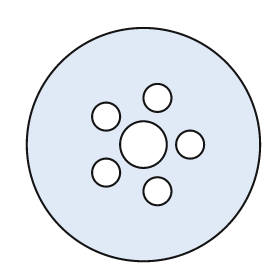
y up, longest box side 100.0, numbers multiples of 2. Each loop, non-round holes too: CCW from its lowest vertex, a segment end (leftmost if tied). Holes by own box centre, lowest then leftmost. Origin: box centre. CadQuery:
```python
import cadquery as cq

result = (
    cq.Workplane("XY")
    .moveTo(0.0, 0.0)
    .circle(50.0)
    .moveTo(6.0, -20.0)
    .circle(6.0)
    .moveTo(-16.0, -12.0)
    .circle(6.0)
    .moveTo(0.0, 0.0)
    .circle(10.0)
    .moveTo(20.0, 0.0)
    .circle(6.0)
    .moveTo(-16.0, 12.0)
    .circle(6.0)
    .moveTo(6.0, 20.0)
    .circle(6.0)
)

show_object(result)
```